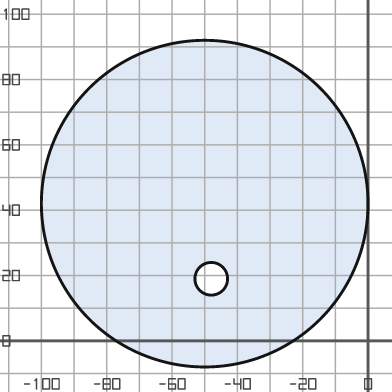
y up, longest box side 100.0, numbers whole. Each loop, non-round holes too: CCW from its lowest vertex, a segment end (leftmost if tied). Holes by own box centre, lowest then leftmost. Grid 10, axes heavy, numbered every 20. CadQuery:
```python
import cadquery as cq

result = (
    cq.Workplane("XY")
    .moveTo(-50.0, 42.0)
    .circle(50.0)
    .moveTo(-48.0, 19.0)
    .circle(5.0)
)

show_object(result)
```